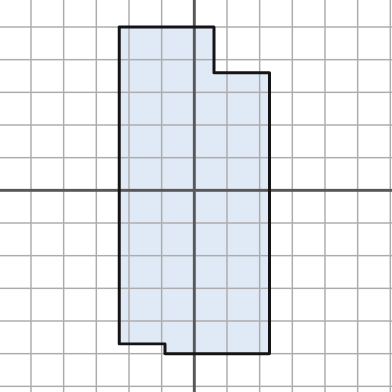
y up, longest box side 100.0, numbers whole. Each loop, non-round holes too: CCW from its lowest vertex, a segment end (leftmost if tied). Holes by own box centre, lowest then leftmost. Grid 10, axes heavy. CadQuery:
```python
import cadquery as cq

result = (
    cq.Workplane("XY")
    .moveTo(-9.0, -50.0)
    .lineTo(23.0, -50.0)
    .lineTo(23.0, 36.0)
    .lineTo(6.0, 36.0)
    .lineTo(6.0, 50.0)
    .lineTo(-23.0, 50.0)
    .lineTo(-23.0, -47.0)
    .lineTo(-9.0, -47.0)
    .close()
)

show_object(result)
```